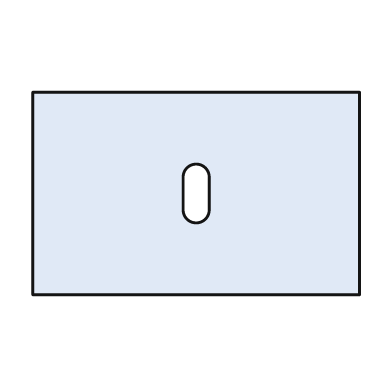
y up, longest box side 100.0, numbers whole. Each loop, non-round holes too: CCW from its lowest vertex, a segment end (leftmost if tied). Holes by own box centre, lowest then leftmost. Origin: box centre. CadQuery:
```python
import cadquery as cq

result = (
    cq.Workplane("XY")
    .moveTo(-50.0, -31.0)
    .lineTo(50.0, -31.0)
    .lineTo(50.0, 31.0)
    .lineTo(-50.0, 31.0)
    .close()
    .moveTo(-4.0, -5.0)
    .threePointArc((0.0, -9.0), (4.0, -5.0))
    .lineTo(4.0, 5.0)
    .threePointArc((0.0, 9.0), (-4.0, 5.0))
    .close()
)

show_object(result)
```